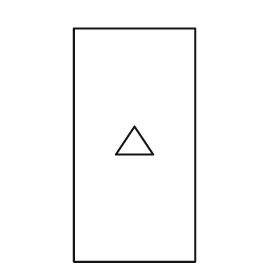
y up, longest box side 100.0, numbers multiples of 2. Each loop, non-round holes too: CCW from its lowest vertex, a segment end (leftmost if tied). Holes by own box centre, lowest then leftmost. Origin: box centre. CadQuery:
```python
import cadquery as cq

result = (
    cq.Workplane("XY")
    .moveTo(-26.0, -50.0)
    .lineTo(26.0, -50.0)
    .lineTo(26.0, 50.0)
    .lineTo(-26.0, 50.0)
    .close()
    .moveTo(-8.0, -4.0)
    .lineTo(8.0, -4.0)
    .lineTo(0.0, 8.0)
    .close()
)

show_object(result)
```